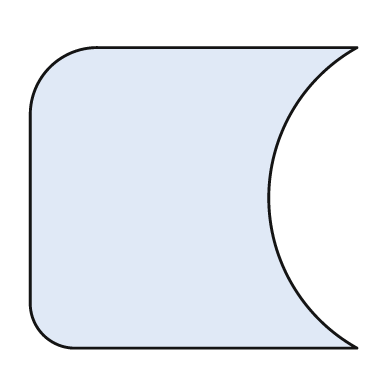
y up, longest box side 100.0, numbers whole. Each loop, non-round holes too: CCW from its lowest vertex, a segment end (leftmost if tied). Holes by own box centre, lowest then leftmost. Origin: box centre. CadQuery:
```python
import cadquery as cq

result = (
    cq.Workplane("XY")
    .moveTo(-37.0, -46.0)
    .lineTo(50.0, -46.0)
    .threePointArc((23.0, 0.0), (50.0, 46.0))
    .lineTo(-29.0, 46.0)
    .threePointArc((-44.0, 40.0), (-50.0, 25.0))
    .lineTo(-50.0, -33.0)
    .threePointArc((-46.0, -42.0), (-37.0, -46.0))
    .close()
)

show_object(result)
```